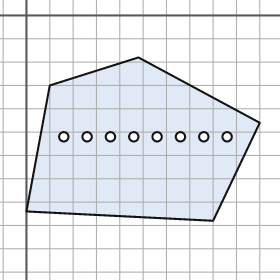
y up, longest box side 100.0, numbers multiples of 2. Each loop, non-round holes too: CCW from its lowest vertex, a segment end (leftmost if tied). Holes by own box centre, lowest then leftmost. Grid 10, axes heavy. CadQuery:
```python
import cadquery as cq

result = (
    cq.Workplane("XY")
    .moveTo(80.0, -88.0)
    .lineTo(100.0, -46.0)
    .lineTo(48.0, -18.0)
    .lineTo(10.0, -30.0)
    .lineTo(0.0, -84.0)
    .close()
    .moveTo(16.0, -52.0)
    .circle(2.0)
    .moveTo(26.0, -52.0)
    .circle(2.0)
    .moveTo(36.0, -52.0)
    .circle(2.0)
    .moveTo(46.0, -52.0)
    .circle(2.0)
    .moveTo(56.0, -52.0)
    .circle(2.0)
    .moveTo(66.0, -52.0)
    .circle(2.0)
    .moveTo(76.0, -52.0)
    .circle(2.0)
    .moveTo(86.0, -52.0)
    .circle(2.0)
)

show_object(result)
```